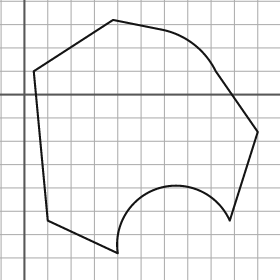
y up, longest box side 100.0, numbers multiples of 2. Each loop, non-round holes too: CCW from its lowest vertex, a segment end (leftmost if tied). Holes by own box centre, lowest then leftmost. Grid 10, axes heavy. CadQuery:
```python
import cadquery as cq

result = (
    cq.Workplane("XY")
    .moveTo(40.0, -68.0)
    .threePointArc((58.0, -40.0), (88.0, -54.0))
    .lineTo(100.0, -16.0)
    .lineTo(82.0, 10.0)
    .threePointArc((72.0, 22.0), (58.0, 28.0))
    .lineTo(38.0, 32.0)
    .lineTo(4.0, 10.0)
    .lineTo(10.0, -54.0)
    .close()
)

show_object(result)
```